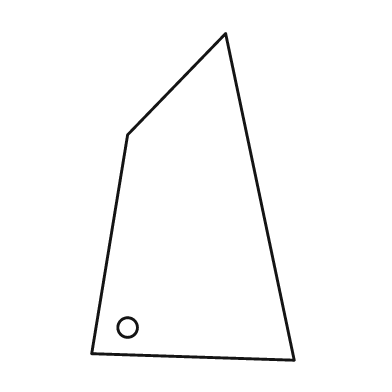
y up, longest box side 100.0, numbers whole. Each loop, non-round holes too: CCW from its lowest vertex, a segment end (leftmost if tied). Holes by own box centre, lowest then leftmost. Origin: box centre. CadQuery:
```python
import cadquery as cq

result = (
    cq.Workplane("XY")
    .moveTo(31.0, -50.0)
    .lineTo(10.0, 50.0)
    .lineTo(-20.0, 19.0)
    .lineTo(-31.0, -48.0)
    .close()
    .moveTo(-20.0, -40.0)
    .circle(3.0)
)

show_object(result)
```